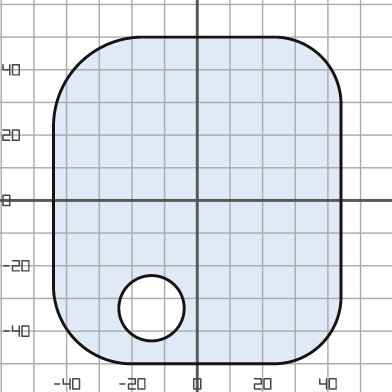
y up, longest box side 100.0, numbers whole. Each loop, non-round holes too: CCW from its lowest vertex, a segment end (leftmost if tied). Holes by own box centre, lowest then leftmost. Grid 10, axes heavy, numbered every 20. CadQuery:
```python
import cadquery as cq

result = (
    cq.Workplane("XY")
    .moveTo(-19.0, -50.0)
    .lineTo(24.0, -50.0)
    .threePointArc((38.0, -44.0), (44.0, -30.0))
    .lineTo(44.0, 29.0)
    .threePointArc((38.0, 44.0), (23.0, 50.0))
    .lineTo(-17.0, 50.0)
    .threePointArc((-36.0, 42.0), (-44.0, 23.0))
    .lineTo(-44.0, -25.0)
    .threePointArc((-37.0, -43.0), (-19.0, -50.0))
    .close()
    .moveTo(-14.0, -33.0)
    .circle(10.0)
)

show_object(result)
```